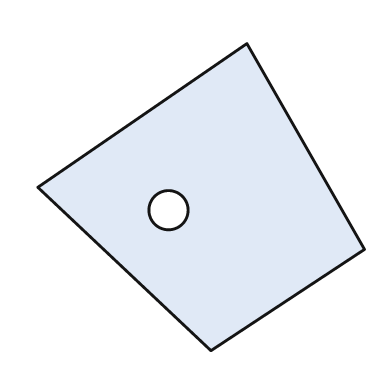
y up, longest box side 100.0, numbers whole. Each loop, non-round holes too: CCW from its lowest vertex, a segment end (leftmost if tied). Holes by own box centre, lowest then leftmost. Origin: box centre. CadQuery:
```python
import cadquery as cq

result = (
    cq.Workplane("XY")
    .moveTo(3.0, -47.0)
    .lineTo(50.0, -16.0)
    .lineTo(14.0, 47.0)
    .lineTo(-50.0, 3.0)
    .close()
    .moveTo(-10.0, -4.0)
    .circle(6.0)
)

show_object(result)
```